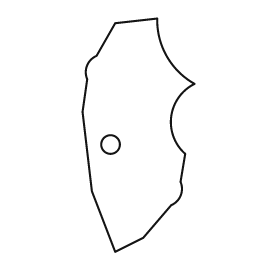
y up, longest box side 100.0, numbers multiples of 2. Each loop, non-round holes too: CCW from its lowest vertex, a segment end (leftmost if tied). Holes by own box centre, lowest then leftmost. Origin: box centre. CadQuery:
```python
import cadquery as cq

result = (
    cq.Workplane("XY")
    .moveTo(-10.0, -50.0)
    .lineTo(2.0, -44.0)
    .lineTo(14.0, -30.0)
    .threePointArc((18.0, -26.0), (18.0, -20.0))
    .lineTo(20.0, -8.0)
    .threePointArc((14.0, 8.0), (24.0, 22.0))
    .threePointArc((12.0, 34.0), (8.0, 50.0))
    .lineTo(-10.0, 48.0)
    .lineTo(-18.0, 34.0)
    .threePointArc((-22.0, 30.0), (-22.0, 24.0))
    .lineTo(-24.0, 10.0)
    .lineTo(-20.0, -24.0)
    .close()
    .moveTo(-12.0, -4.0)
    .circle(4.0)
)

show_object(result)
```